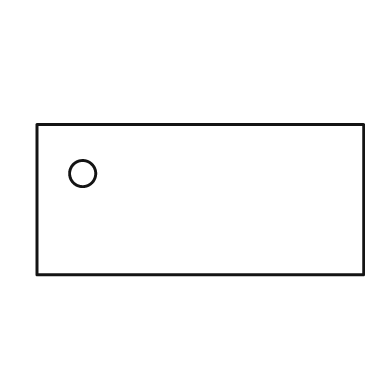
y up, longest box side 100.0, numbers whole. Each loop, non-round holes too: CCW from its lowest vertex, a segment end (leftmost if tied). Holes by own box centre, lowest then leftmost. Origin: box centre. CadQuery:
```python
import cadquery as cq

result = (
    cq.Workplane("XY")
    .moveTo(-50.0, -23.0)
    .lineTo(50.0, -23.0)
    .lineTo(50.0, 23.0)
    .lineTo(-50.0, 23.0)
    .close()
    .moveTo(-36.0, 8.0)
    .circle(4.0)
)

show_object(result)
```